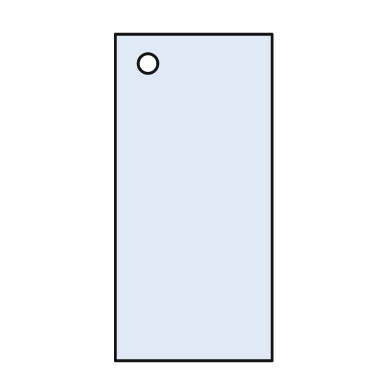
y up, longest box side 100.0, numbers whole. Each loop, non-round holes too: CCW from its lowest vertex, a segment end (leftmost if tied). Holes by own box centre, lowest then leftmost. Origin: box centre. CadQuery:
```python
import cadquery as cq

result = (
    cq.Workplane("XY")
    .moveTo(-24.0, -50.0)
    .lineTo(24.0, -50.0)
    .lineTo(24.0, 50.0)
    .lineTo(-24.0, 50.0)
    .close()
    .moveTo(-14.0, 41.0)
    .circle(3.0)
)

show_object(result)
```